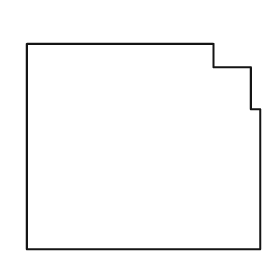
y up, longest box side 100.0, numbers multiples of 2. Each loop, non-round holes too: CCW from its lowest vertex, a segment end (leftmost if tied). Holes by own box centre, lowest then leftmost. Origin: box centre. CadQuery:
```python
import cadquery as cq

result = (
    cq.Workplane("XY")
    .moveTo(-50.0, -44.0)
    .lineTo(50.0, -44.0)
    .lineTo(50.0, 16.0)
    .lineTo(46.0, 16.0)
    .lineTo(46.0, 34.0)
    .lineTo(30.0, 34.0)
    .lineTo(30.0, 44.0)
    .lineTo(-50.0, 44.0)
    .close()
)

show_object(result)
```